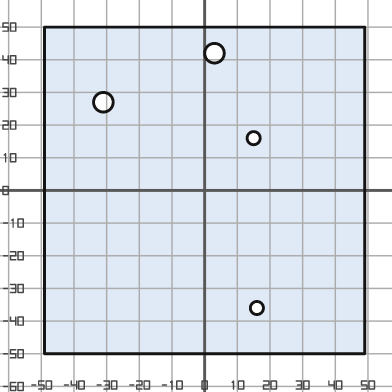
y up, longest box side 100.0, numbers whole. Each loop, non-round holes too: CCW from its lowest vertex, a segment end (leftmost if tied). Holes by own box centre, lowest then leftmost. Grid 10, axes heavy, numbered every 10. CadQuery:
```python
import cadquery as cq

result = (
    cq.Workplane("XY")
    .moveTo(-49.0, -50.0)
    .lineTo(49.0, -50.0)
    .lineTo(49.0, 50.0)
    .lineTo(-49.0, 50.0)
    .close()
    .moveTo(16.0, -36.0)
    .circle(2.0)
    .moveTo(15.0, 16.0)
    .circle(2.0)
    .moveTo(-31.0, 27.0)
    .circle(3.0)
    .moveTo(3.0, 42.0)
    .circle(3.0)
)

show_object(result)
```